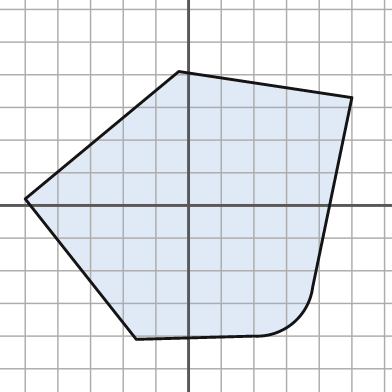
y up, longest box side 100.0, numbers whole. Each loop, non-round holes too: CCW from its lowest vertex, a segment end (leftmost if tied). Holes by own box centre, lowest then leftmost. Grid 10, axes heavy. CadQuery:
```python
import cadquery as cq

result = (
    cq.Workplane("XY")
    .moveTo(-16.0, -41.0)
    .lineTo(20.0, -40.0)
    .threePointArc((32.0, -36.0), (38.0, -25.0))
    .lineTo(50.0, 33.0)
    .lineTo(-3.0, 41.0)
    .lineTo(-50.0, 2.0)
    .close()
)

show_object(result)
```